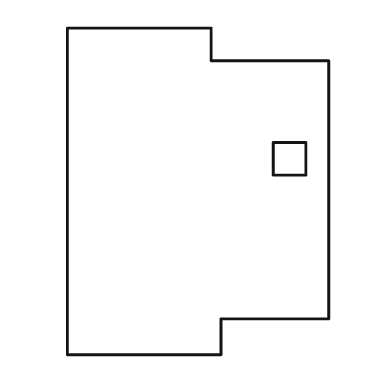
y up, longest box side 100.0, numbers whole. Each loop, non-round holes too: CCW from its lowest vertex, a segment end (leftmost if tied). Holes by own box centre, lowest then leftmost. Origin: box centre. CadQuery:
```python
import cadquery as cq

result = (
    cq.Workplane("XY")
    .moveTo(-40.0, -50.0)
    .lineTo(7.0, -50.0)
    .lineTo(7.0, -39.0)
    .lineTo(40.0, -39.0)
    .lineTo(40.0, 40.0)
    .lineTo(4.0, 40.0)
    .lineTo(4.0, 50.0)
    .lineTo(-40.0, 50.0)
    .close()
    .moveTo(23.0, 5.0)
    .lineTo(33.0, 5.0)
    .lineTo(33.0, 15.0)
    .lineTo(23.0, 15.0)
    .close()
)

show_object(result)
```